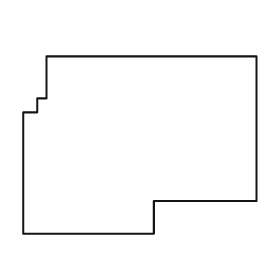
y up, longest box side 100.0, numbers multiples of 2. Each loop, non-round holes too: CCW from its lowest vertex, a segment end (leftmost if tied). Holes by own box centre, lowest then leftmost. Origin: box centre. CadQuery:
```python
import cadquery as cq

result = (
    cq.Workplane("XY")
    .moveTo(-50.0, -38.0)
    .lineTo(6.0, -38.0)
    .lineTo(6.0, -24.0)
    .lineTo(50.0, -24.0)
    .lineTo(50.0, 38.0)
    .lineTo(-40.0, 38.0)
    .lineTo(-40.0, 20.0)
    .lineTo(-44.0, 20.0)
    .lineTo(-44.0, 14.0)
    .lineTo(-50.0, 14.0)
    .close()
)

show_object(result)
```